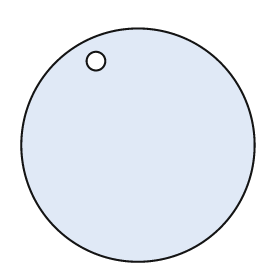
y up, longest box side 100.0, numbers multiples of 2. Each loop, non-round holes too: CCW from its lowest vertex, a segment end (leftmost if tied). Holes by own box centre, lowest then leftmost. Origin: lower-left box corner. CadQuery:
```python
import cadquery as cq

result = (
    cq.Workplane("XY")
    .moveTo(50.0, 50.0)
    .circle(50.0)
    .moveTo(32.0, 86.0)
    .circle(4.0)
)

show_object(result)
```